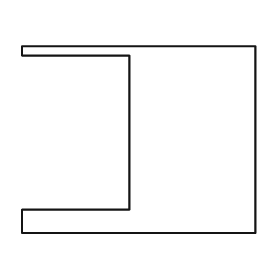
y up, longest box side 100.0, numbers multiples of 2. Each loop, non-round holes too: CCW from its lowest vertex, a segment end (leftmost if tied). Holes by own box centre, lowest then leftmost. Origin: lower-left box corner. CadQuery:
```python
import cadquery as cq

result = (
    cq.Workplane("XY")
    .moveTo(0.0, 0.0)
    .lineTo(100.0, 0.0)
    .lineTo(100.0, 80.0)
    .lineTo(0.0, 80.0)
    .lineTo(0.0, 76.0)
    .lineTo(46.0, 76.0)
    .lineTo(46.0, 10.0)
    .lineTo(0.0, 10.0)
    .close()
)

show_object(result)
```